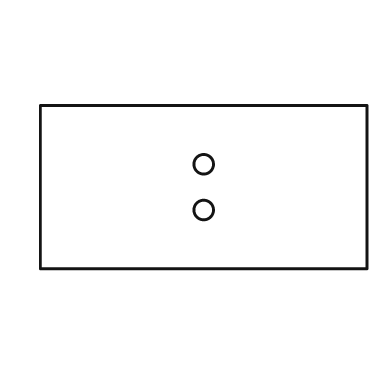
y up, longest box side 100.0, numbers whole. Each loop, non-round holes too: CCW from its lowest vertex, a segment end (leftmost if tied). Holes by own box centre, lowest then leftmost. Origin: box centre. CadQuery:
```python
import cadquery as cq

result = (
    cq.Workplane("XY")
    .moveTo(-50.0, -25.0)
    .lineTo(50.0, -25.0)
    .lineTo(50.0, 25.0)
    .lineTo(-50.0, 25.0)
    .close()
    .moveTo(0.0, -7.0)
    .circle(3.0)
    .moveTo(0.0, 7.0)
    .circle(3.0)
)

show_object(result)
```